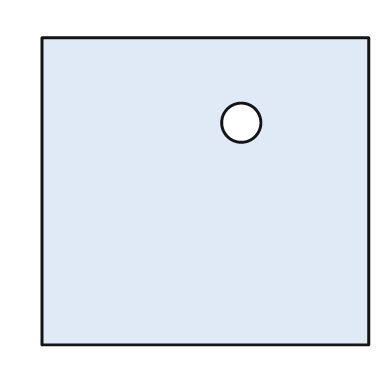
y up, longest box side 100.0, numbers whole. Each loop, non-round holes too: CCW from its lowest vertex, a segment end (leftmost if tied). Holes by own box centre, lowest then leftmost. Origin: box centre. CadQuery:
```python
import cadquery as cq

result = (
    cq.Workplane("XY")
    .moveTo(-50.0, -47.0)
    .lineTo(50.0, -47.0)
    .lineTo(50.0, 47.0)
    .lineTo(-50.0, 47.0)
    .close()
    .moveTo(11.0, 21.0)
    .circle(6.0)
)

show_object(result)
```